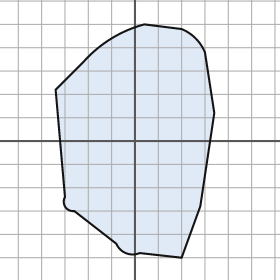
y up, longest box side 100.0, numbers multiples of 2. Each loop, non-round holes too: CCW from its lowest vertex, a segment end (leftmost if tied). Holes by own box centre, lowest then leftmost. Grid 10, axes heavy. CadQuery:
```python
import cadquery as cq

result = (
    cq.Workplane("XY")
    .moveTo(20.0, -50.0)
    .lineTo(28.0, -28.0)
    .lineTo(34.0, 12.0)
    .lineTo(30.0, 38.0)
    .threePointArc((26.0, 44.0), (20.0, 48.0))
    .lineTo(4.0, 50.0)
    .threePointArc((-10.0, 44.0), (-22.0, 34.0))
    .lineTo(-34.0, 22.0)
    .lineTo(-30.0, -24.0)
    .threePointArc((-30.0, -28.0), (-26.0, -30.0))
    .lineTo(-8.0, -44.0)
    .threePointArc((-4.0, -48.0), (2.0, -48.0))
    .close()
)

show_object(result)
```